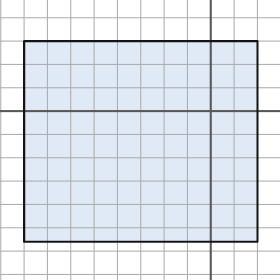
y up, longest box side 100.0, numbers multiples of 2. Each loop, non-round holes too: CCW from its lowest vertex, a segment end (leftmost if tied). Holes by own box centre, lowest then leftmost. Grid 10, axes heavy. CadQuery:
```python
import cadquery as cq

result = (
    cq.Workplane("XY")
    .moveTo(-80.0, -56.0)
    .lineTo(20.0, -56.0)
    .lineTo(20.0, 30.0)
    .lineTo(-80.0, 30.0)
    .close()
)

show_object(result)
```